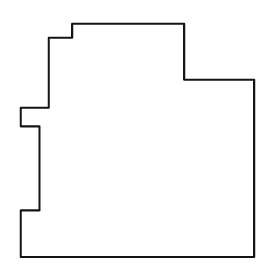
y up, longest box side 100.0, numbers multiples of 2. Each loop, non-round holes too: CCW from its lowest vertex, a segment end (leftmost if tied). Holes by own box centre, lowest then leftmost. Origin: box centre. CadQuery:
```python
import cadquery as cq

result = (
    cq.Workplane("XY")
    .moveTo(-50.0, -50.0)
    .lineTo(50.0, -50.0)
    .lineTo(50.0, 26.0)
    .lineTo(20.0, 26.0)
    .lineTo(20.0, 50.0)
    .lineTo(-28.0, 50.0)
    .lineTo(-28.0, 44.0)
    .lineTo(-38.0, 44.0)
    .lineTo(-38.0, 14.0)
    .lineTo(-50.0, 14.0)
    .lineTo(-50.0, 6.0)
    .lineTo(-42.0, 6.0)
    .lineTo(-42.0, -30.0)
    .lineTo(-50.0, -30.0)
    .close()
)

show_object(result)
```